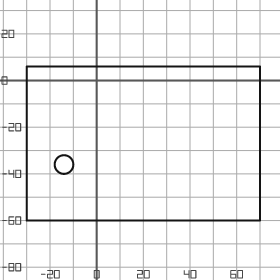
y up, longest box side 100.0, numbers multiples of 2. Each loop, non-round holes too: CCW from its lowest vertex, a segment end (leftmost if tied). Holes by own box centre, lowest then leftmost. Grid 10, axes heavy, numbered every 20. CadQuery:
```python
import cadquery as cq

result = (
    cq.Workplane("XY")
    .moveTo(-30.0, -60.0)
    .lineTo(70.0, -60.0)
    .lineTo(70.0, 6.0)
    .lineTo(-30.0, 6.0)
    .close()
    .moveTo(-14.0, -36.0)
    .circle(4.0)
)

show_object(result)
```